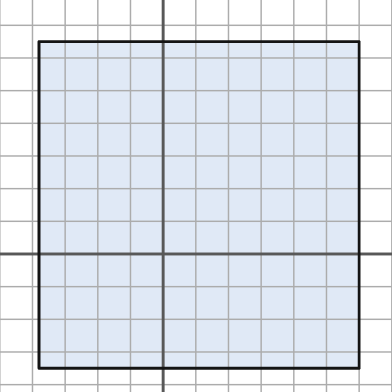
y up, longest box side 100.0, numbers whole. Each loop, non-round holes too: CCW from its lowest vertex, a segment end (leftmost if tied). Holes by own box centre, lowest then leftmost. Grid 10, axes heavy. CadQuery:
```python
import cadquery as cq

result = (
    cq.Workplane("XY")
    .moveTo(-38.0, -35.0)
    .lineTo(60.0, -35.0)
    .lineTo(60.0, 65.0)
    .lineTo(-38.0, 65.0)
    .close()
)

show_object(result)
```